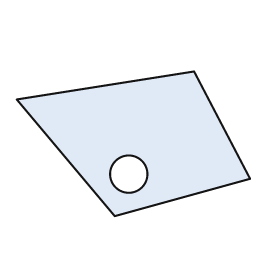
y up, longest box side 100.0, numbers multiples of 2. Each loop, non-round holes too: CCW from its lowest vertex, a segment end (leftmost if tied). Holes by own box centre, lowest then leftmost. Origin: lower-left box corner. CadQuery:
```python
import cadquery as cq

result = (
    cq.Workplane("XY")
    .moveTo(42.0, 0.0)
    .lineTo(100.0, 16.0)
    .lineTo(76.0, 62.0)
    .lineTo(0.0, 50.0)
    .close()
    .moveTo(48.0, 18.0)
    .circle(8.0)
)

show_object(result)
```